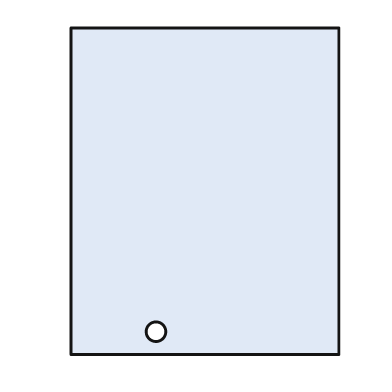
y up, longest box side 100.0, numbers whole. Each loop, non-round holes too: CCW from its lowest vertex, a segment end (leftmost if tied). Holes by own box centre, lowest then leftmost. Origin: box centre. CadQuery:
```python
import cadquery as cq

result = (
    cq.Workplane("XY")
    .moveTo(-41.0, -50.0)
    .lineTo(41.0, -50.0)
    .lineTo(41.0, 50.0)
    .lineTo(-41.0, 50.0)
    .close()
    .moveTo(-15.0, -43.0)
    .circle(3.0)
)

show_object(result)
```